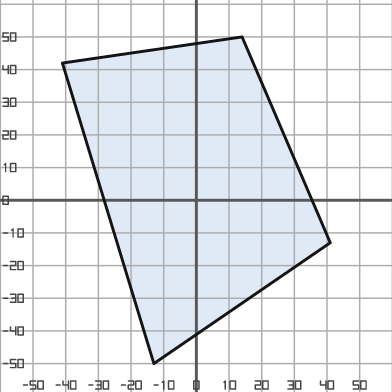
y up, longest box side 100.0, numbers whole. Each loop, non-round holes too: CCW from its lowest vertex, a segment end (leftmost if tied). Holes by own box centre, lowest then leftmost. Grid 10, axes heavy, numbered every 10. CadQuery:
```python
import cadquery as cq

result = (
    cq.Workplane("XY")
    .moveTo(-13.0, -50.0)
    .lineTo(41.0, -13.0)
    .lineTo(14.0, 50.0)
    .lineTo(-41.0, 42.0)
    .close()
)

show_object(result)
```